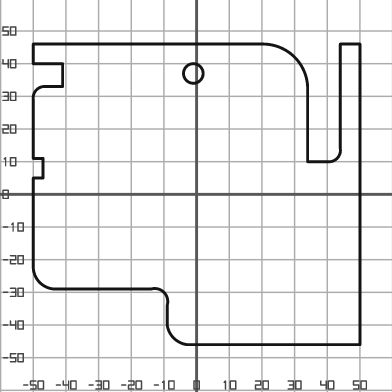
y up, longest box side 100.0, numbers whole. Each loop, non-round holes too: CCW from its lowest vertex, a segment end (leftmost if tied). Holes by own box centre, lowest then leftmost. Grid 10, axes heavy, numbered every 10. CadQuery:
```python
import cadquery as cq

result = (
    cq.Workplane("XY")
    .moveTo(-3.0, -46.0)
    .lineTo(50.0, -46.0)
    .lineTo(50.0, 46.0)
    .lineTo(44.0, 46.0)
    .lineTo(44.0, 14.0)
    .threePointArc((43.0, 11.0), (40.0, 10.0))
    .lineTo(34.0, 10.0)
    .lineTo(34.0, 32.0)
    .threePointArc((30.0, 42.0), (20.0, 46.0))
    .lineTo(-50.0, 46.0)
    .lineTo(-50.0, 40.0)
    .lineTo(-41.0, 40.0)
    .lineTo(-41.0, 33.0)
    .lineTo(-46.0, 33.0)
    .threePointArc((-49.0, 32.0), (-50.0, 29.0))
    .lineTo(-50.0, 11.0)
    .lineTo(-47.0, 11.0)
    .lineTo(-47.0, 5.0)
    .lineTo(-50.0, 5.0)
    .lineTo(-50.0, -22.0)
    .threePointArc((-48.0, -27.0), (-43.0, -29.0))
    .lineTo(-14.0, -29.0)
    .threePointArc((-10.0, -30.0), (-9.0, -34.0))
    .lineTo(-9.0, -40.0)
    .threePointArc((-7.0, -44.0), (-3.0, -46.0))
    .close()
    .moveTo(-1.0, 37.0)
    .circle(3.0)
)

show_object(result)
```